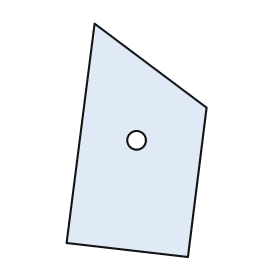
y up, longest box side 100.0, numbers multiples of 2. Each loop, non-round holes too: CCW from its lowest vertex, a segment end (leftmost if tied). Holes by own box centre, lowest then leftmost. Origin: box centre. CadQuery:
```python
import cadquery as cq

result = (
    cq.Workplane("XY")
    .moveTo(22.0, -50.0)
    .lineTo(30.0, 14.0)
    .lineTo(-18.0, 50.0)
    .lineTo(-30.0, -44.0)
    .close()
    .moveTo(0.0, 0.0)
    .circle(4.0)
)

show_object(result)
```